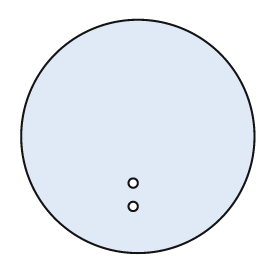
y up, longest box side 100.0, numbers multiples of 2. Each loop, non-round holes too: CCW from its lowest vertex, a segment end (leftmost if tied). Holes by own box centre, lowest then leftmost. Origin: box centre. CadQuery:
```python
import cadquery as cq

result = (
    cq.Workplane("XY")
    .moveTo(0.0, 0.0)
    .circle(50.0)
    .moveTo(-2.0, -30.0)
    .circle(2.0)
    .moveTo(-2.0, -20.0)
    .circle(2.0)
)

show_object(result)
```